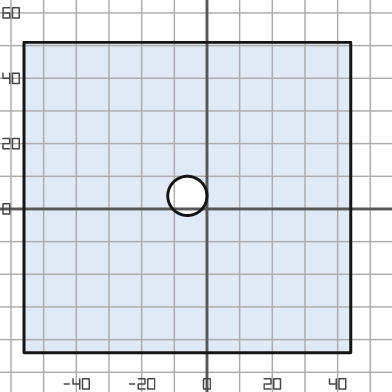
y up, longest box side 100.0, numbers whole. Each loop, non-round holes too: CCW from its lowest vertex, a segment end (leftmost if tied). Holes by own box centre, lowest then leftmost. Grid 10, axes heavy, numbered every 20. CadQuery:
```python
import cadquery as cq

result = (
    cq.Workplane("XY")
    .moveTo(-56.0, -44.0)
    .lineTo(44.0, -44.0)
    .lineTo(44.0, 51.0)
    .lineTo(-56.0, 51.0)
    .close()
    .moveTo(-6.0, 4.0)
    .circle(6.0)
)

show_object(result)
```